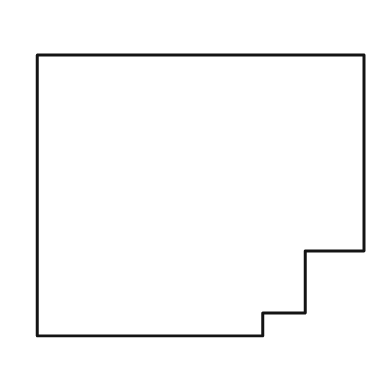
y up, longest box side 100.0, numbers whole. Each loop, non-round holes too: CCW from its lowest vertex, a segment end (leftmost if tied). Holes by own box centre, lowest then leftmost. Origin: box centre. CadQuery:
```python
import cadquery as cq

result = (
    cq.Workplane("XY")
    .moveTo(-50.0, -43.0)
    .lineTo(19.0, -43.0)
    .lineTo(19.0, -36.0)
    .lineTo(32.0, -36.0)
    .lineTo(32.0, -17.0)
    .lineTo(50.0, -17.0)
    .lineTo(50.0, 43.0)
    .lineTo(-50.0, 43.0)
    .close()
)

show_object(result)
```